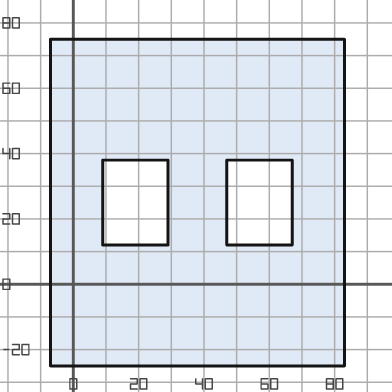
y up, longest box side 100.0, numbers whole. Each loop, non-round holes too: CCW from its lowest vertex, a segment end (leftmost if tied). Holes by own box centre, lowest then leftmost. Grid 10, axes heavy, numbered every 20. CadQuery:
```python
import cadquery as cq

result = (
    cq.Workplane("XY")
    .moveTo(-7.0, -25.0)
    .lineTo(83.0, -25.0)
    .lineTo(83.0, 75.0)
    .lineTo(-7.0, 75.0)
    .close()
    .moveTo(9.0, 12.0)
    .lineTo(29.0, 12.0)
    .lineTo(29.0, 38.0)
    .lineTo(9.0, 38.0)
    .close()
    .moveTo(47.0, 12.0)
    .lineTo(67.0, 12.0)
    .lineTo(67.0, 38.0)
    .lineTo(47.0, 38.0)
    .close()
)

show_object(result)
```